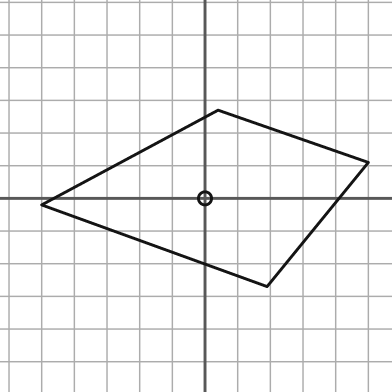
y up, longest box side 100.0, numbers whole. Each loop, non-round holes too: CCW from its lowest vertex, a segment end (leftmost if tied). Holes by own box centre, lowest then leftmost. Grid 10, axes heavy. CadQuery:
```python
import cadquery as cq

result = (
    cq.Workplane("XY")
    .moveTo(19.0, -27.0)
    .lineTo(50.0, 11.0)
    .lineTo(4.0, 27.0)
    .lineTo(-50.0, -2.0)
    .close()
    .moveTo(0.0, 0.0)
    .circle(2.0)
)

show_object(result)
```